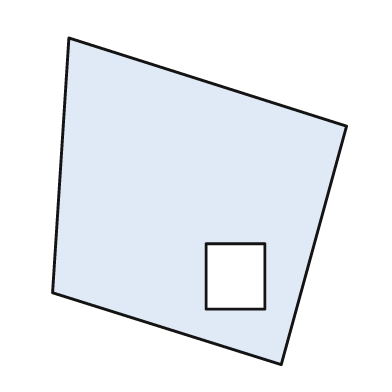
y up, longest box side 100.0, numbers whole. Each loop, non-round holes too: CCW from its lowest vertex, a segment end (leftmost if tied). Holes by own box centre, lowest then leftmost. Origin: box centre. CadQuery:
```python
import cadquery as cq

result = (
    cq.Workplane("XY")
    .moveTo(25.0, -50.0)
    .lineTo(45.0, 23.0)
    .lineTo(-40.0, 50.0)
    .lineTo(-45.0, -28.0)
    .close()
    .moveTo(2.0, -33.0)
    .lineTo(20.0, -33.0)
    .lineTo(20.0, -13.0)
    .lineTo(2.0, -13.0)
    .close()
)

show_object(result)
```